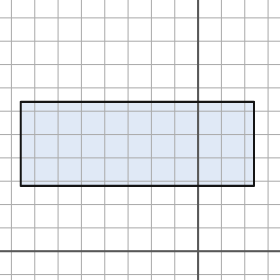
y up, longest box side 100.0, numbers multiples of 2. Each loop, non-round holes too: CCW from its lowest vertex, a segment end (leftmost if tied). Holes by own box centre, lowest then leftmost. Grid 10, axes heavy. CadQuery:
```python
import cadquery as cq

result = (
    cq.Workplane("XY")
    .moveTo(-76.0, 28.0)
    .lineTo(24.0, 28.0)
    .lineTo(24.0, 64.0)
    .lineTo(-76.0, 64.0)
    .close()
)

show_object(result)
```